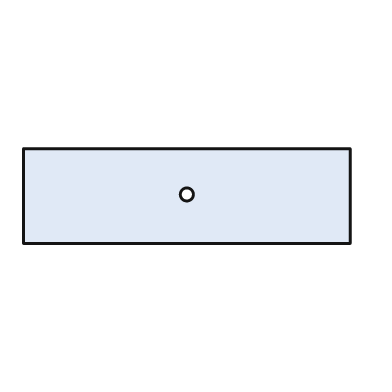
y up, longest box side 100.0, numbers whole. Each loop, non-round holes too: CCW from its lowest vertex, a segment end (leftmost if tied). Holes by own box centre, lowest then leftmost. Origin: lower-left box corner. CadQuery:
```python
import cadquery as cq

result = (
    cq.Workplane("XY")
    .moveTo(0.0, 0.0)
    .lineTo(100.0, 0.0)
    .lineTo(100.0, 29.0)
    .lineTo(0.0, 29.0)
    .close()
    .moveTo(50.0, 15.0)
    .circle(2.0)
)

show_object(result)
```